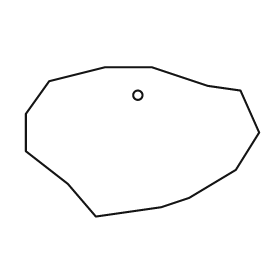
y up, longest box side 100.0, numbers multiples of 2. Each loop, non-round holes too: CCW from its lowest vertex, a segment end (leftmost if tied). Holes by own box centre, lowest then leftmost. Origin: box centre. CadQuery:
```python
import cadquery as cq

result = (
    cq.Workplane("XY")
    .moveTo(-20.0, -32.0)
    .lineTo(8.0, -28.0)
    .lineTo(20.0, -24.0)
    .lineTo(40.0, -12.0)
    .lineTo(50.0, 4.0)
    .lineTo(42.0, 22.0)
    .lineTo(28.0, 24.0)
    .lineTo(4.0, 32.0)
    .lineTo(-16.0, 32.0)
    .lineTo(-40.0, 26.0)
    .lineTo(-50.0, 12.0)
    .lineTo(-50.0, -4.0)
    .lineTo(-32.0, -18.0)
    .close()
    .moveTo(-2.0, 20.0)
    .circle(2.0)
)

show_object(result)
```